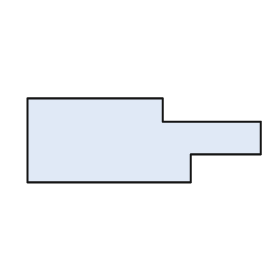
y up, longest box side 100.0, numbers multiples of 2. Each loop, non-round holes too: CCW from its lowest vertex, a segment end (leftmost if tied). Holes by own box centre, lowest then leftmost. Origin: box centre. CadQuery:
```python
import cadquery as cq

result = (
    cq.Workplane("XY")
    .moveTo(-50.0, -18.0)
    .lineTo(20.0, -18.0)
    .lineTo(20.0, -6.0)
    .lineTo(50.0, -6.0)
    .lineTo(50.0, 8.0)
    .lineTo(8.0, 8.0)
    .lineTo(8.0, 18.0)
    .lineTo(-50.0, 18.0)
    .close()
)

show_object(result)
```